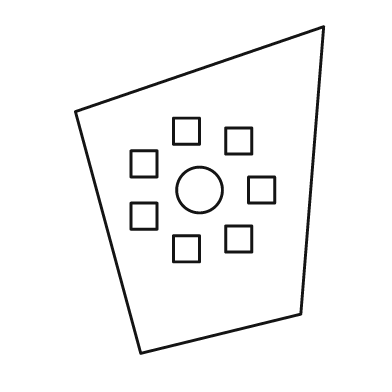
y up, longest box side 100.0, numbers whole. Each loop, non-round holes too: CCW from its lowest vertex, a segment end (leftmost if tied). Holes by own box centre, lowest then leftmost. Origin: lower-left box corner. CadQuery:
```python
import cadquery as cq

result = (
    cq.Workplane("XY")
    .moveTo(20.0, 0.0)
    .lineTo(69.0, 12.0)
    .lineTo(76.0, 100.0)
    .lineTo(0.0, 74.0)
    .close()
    .moveTo(30.0, 28.0)
    .lineTo(38.0, 28.0)
    .lineTo(38.0, 36.0)
    .lineTo(30.0, 36.0)
    .close()
    .moveTo(46.0, 31.0)
    .lineTo(54.0, 31.0)
    .lineTo(54.0, 39.0)
    .lineTo(46.0, 39.0)
    .close()
    .moveTo(17.0, 38.0)
    .lineTo(25.0, 38.0)
    .lineTo(25.0, 46.0)
    .lineTo(17.0, 46.0)
    .close()
    .moveTo(38.0, 50.0)
    .circle(7.0)
    .moveTo(53.0, 46.0)
    .lineTo(61.0, 46.0)
    .lineTo(61.0, 54.0)
    .lineTo(53.0, 54.0)
    .close()
    .moveTo(17.0, 54.0)
    .lineTo(25.0, 54.0)
    .lineTo(25.0, 62.0)
    .lineTo(17.0, 62.0)
    .close()
    .moveTo(46.0, 61.0)
    .lineTo(54.0, 61.0)
    .lineTo(54.0, 69.0)
    .lineTo(46.0, 69.0)
    .close()
    .moveTo(30.0, 64.0)
    .lineTo(38.0, 64.0)
    .lineTo(38.0, 72.0)
    .lineTo(30.0, 72.0)
    .close()
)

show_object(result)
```